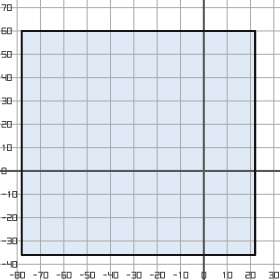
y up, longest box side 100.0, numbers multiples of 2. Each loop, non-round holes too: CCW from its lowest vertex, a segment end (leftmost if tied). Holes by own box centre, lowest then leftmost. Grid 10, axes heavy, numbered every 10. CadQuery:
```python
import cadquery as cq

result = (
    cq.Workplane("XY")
    .moveTo(-78.0, -36.0)
    .lineTo(22.0, -36.0)
    .lineTo(22.0, 60.0)
    .lineTo(-78.0, 60.0)
    .close()
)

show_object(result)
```